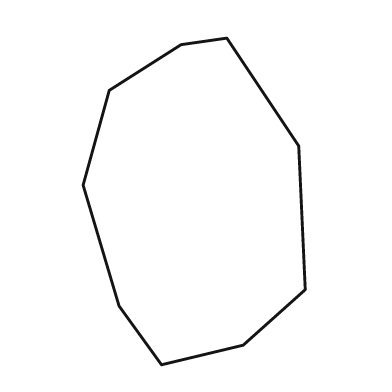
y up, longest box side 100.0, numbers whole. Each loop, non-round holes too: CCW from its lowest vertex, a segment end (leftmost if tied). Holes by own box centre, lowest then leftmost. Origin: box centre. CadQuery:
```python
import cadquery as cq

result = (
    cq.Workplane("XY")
    .moveTo(-10.0, -50.0)
    .lineTo(15.0, -44.0)
    .lineTo(34.0, -27.0)
    .lineTo(32.0, 17.0)
    .lineTo(10.0, 50.0)
    .lineTo(-4.0, 48.0)
    .lineTo(-26.0, 34.0)
    .lineTo(-34.0, 5.0)
    .lineTo(-23.0, -32.0)
    .close()
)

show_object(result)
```